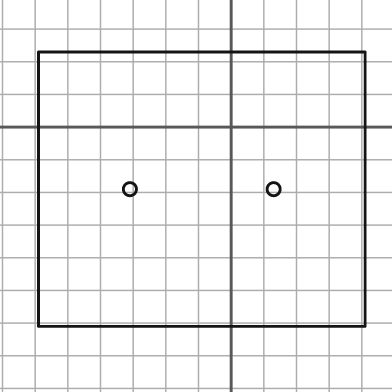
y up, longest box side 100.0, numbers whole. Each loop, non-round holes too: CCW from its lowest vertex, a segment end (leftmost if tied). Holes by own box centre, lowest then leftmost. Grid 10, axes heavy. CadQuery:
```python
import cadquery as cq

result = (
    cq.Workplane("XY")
    .moveTo(-59.0, -61.0)
    .lineTo(41.0, -61.0)
    .lineTo(41.0, 23.0)
    .lineTo(-59.0, 23.0)
    .close()
    .moveTo(-31.0, -19.0)
    .circle(2.0)
    .moveTo(13.0, -19.0)
    .circle(2.0)
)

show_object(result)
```